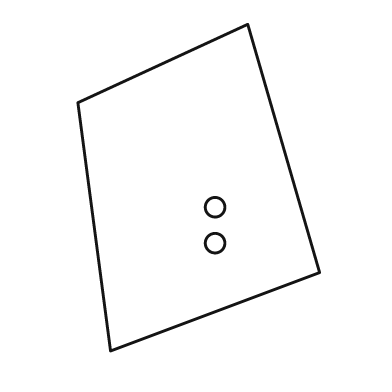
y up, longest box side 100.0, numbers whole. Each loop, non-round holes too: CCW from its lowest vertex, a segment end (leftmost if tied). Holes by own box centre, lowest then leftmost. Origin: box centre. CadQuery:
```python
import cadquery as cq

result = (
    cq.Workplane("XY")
    .moveTo(-27.0, -50.0)
    .lineTo(37.0, -26.0)
    .lineTo(15.0, 50.0)
    .lineTo(-37.0, 26.0)
    .close()
    .moveTo(5.0, -17.0)
    .circle(3.0)
    .moveTo(5.0, -6.0)
    .circle(3.0)
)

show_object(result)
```